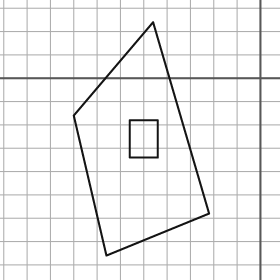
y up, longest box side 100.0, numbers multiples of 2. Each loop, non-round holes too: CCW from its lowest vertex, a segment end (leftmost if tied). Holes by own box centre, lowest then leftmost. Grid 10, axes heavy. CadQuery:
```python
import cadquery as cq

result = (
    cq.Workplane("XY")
    .moveTo(-66.0, -76.0)
    .lineTo(-22.0, -58.0)
    .lineTo(-46.0, 24.0)
    .lineTo(-80.0, -16.0)
    .close()
    .moveTo(-56.0, -34.0)
    .lineTo(-44.0, -34.0)
    .lineTo(-44.0, -18.0)
    .lineTo(-56.0, -18.0)
    .close()
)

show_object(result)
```